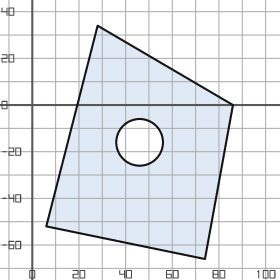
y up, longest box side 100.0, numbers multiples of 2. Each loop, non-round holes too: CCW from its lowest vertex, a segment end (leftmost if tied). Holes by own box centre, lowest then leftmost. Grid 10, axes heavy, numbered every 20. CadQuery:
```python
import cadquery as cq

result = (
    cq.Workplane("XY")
    .moveTo(74.0, -66.0)
    .lineTo(86.0, 0.0)
    .lineTo(28.0, 34.0)
    .lineTo(6.0, -52.0)
    .close()
    .moveTo(46.0, -16.0)
    .circle(10.0)
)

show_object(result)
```